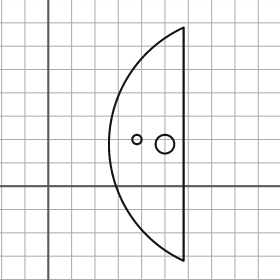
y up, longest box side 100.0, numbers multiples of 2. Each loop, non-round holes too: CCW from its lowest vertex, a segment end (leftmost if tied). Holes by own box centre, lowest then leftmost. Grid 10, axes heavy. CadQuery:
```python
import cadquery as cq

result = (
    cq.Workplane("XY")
    .moveTo(58.0, -32.0)
    .lineTo(58.0, 68.0)
    .threePointArc((26.0, 18.0), (58.0, -32.0))
    .close()
    .moveTo(50.0, 18.0)
    .circle(4.0)
    .moveTo(38.0, 20.0)
    .circle(2.0)
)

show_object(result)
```